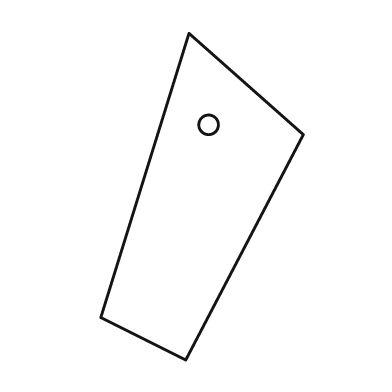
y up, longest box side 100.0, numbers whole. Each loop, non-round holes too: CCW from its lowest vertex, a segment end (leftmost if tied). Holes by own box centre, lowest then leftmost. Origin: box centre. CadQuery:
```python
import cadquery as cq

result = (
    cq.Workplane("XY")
    .moveTo(-5.0, -50.0)
    .lineTo(31.0, 19.0)
    .lineTo(-4.0, 50.0)
    .lineTo(-31.0, -37.0)
    .close()
    .moveTo(2.0, 22.0)
    .circle(3.0)
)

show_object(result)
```